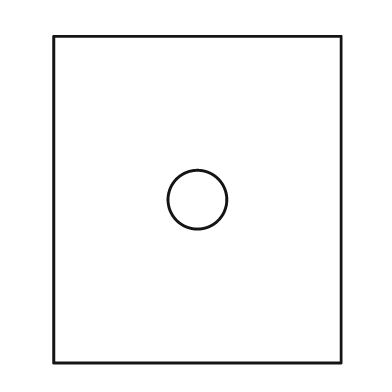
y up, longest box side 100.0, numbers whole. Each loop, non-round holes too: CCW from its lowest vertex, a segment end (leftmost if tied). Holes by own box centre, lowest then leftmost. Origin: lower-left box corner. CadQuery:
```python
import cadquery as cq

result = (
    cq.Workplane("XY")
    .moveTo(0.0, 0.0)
    .lineTo(88.0, 0.0)
    .lineTo(88.0, 100.0)
    .lineTo(0.0, 100.0)
    .close()
    .moveTo(44.0, 50.0)
    .circle(9.0)
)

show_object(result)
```